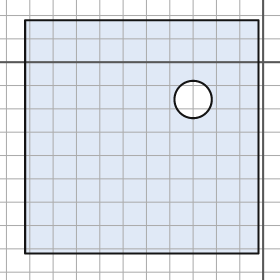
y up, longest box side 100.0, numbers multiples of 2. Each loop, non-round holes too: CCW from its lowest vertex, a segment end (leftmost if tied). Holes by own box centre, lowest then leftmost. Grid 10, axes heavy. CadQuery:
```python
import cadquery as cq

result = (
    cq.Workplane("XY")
    .moveTo(-102.0, -82.0)
    .lineTo(-2.0, -82.0)
    .lineTo(-2.0, 18.0)
    .lineTo(-102.0, 18.0)
    .close()
    .moveTo(-30.0, -16.0)
    .circle(8.0)
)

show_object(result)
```